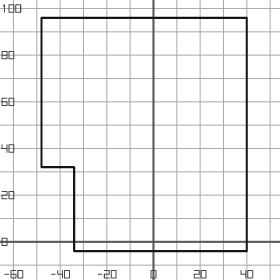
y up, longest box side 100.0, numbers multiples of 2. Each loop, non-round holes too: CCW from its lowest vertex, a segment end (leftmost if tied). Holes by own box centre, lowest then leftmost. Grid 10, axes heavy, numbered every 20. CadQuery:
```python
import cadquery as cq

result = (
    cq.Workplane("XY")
    .moveTo(-34.0, -4.0)
    .lineTo(40.0, -4.0)
    .lineTo(40.0, 96.0)
    .lineTo(-48.0, 96.0)
    .lineTo(-48.0, 32.0)
    .lineTo(-34.0, 32.0)
    .close()
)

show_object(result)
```